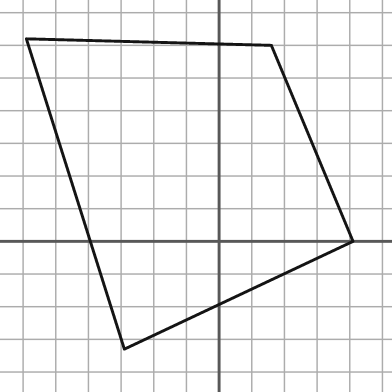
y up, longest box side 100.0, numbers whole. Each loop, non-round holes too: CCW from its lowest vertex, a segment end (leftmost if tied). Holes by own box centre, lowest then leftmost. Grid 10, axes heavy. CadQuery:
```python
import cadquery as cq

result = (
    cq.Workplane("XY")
    .moveTo(-29.0, -33.0)
    .lineTo(41.0, 0.0)
    .lineTo(16.0, 60.0)
    .lineTo(-59.0, 62.0)
    .close()
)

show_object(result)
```